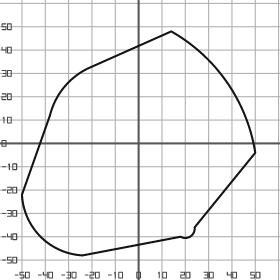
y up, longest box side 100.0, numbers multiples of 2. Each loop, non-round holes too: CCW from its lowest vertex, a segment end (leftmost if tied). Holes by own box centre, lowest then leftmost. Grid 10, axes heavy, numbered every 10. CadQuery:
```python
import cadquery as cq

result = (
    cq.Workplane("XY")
    .moveTo(-24.0, -48.0)
    .lineTo(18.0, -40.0)
    .threePointArc((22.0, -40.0), (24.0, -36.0))
    .lineTo(50.0, -4.0)
    .threePointArc((38.0, 26.0), (14.0, 48.0))
    .lineTo(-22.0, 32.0)
    .threePointArc((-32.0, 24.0), (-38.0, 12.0))
    .lineTo(-50.0, -22.0)
    .threePointArc((-42.0, -40.0), (-24.0, -48.0))
    .close()
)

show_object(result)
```